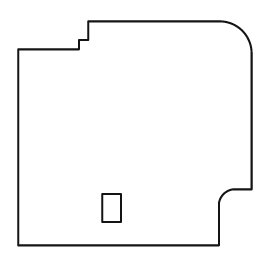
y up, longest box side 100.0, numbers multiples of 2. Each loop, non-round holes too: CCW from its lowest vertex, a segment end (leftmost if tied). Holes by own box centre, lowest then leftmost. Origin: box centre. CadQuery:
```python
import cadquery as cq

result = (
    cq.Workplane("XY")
    .moveTo(-50.0, -48.0)
    .lineTo(36.0, -48.0)
    .lineTo(36.0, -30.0)
    .threePointArc((38.0, -26.0), (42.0, -24.0))
    .lineTo(50.0, -24.0)
    .lineTo(50.0, 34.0)
    .threePointArc((46.0, 44.0), (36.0, 48.0))
    .lineTo(-20.0, 48.0)
    .lineTo(-20.0, 40.0)
    .lineTo(-24.0, 40.0)
    .lineTo(-24.0, 36.0)
    .lineTo(-50.0, 36.0)
    .close()
    .moveTo(-14.0, -38.0)
    .lineTo(-6.0, -38.0)
    .lineTo(-6.0, -26.0)
    .lineTo(-14.0, -26.0)
    .close()
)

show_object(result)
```